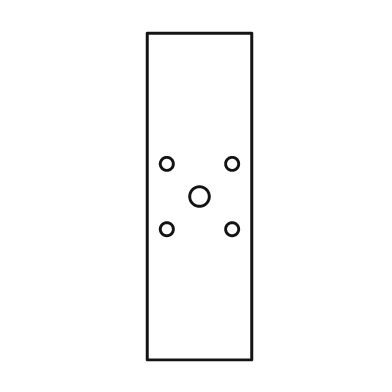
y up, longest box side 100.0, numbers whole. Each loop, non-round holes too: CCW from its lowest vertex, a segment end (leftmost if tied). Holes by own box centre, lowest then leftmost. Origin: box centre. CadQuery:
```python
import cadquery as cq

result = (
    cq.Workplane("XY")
    .moveTo(-16.0, -50.0)
    .lineTo(16.0, -50.0)
    .lineTo(16.0, 50.0)
    .lineTo(-16.0, 50.0)
    .close()
    .moveTo(-10.0, -10.0)
    .circle(2.0)
    .moveTo(10.0, -10.0)
    .circle(2.0)
    .moveTo(0.0, 0.0)
    .circle(3.0)
    .moveTo(-10.0, 10.0)
    .circle(2.0)
    .moveTo(10.0, 10.0)
    .circle(2.0)
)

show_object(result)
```